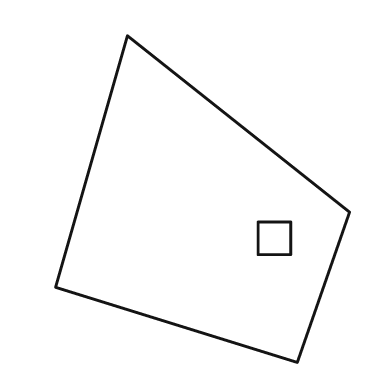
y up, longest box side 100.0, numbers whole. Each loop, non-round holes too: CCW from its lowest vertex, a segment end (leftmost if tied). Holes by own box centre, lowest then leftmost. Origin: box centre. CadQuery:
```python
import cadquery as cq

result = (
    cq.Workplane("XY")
    .moveTo(29.0, -50.0)
    .lineTo(45.0, -4.0)
    .lineTo(-23.0, 50.0)
    .lineTo(-45.0, -27.0)
    .close()
    .moveTo(17.0, -17.0)
    .lineTo(27.0, -17.0)
    .lineTo(27.0, -7.0)
    .lineTo(17.0, -7.0)
    .close()
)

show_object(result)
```